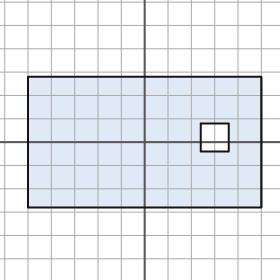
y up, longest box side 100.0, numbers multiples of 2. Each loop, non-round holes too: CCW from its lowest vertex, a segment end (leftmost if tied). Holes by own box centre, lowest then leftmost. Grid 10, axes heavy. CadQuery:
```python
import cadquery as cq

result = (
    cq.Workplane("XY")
    .moveTo(-50.0, -28.0)
    .lineTo(50.0, -28.0)
    .lineTo(50.0, 28.0)
    .lineTo(-50.0, 28.0)
    .close()
    .moveTo(24.0, -4.0)
    .lineTo(36.0, -4.0)
    .lineTo(36.0, 8.0)
    .lineTo(24.0, 8.0)
    .close()
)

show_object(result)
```